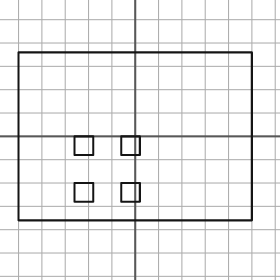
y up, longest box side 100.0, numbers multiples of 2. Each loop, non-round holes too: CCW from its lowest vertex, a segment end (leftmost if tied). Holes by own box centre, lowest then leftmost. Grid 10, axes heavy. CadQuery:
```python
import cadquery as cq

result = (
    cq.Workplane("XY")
    .moveTo(-50.0, -36.0)
    .lineTo(50.0, -36.0)
    .lineTo(50.0, 36.0)
    .lineTo(-50.0, 36.0)
    .close()
    .moveTo(-26.0, -28.0)
    .lineTo(-18.0, -28.0)
    .lineTo(-18.0, -20.0)
    .lineTo(-26.0, -20.0)
    .close()
    .moveTo(-6.0, -28.0)
    .lineTo(2.0, -28.0)
    .lineTo(2.0, -20.0)
    .lineTo(-6.0, -20.0)
    .close()
    .moveTo(-26.0, -8.0)
    .lineTo(-18.0, -8.0)
    .lineTo(-18.0, 0.0)
    .lineTo(-26.0, 0.0)
    .close()
    .moveTo(-6.0, -8.0)
    .lineTo(2.0, -8.0)
    .lineTo(2.0, 0.0)
    .lineTo(-6.0, 0.0)
    .close()
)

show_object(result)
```